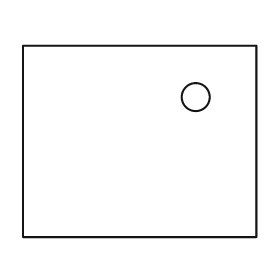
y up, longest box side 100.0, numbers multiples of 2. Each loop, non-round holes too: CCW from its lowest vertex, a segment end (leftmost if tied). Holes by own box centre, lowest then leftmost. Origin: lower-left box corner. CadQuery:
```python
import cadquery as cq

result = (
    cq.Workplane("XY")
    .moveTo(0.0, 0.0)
    .lineTo(100.0, 0.0)
    .lineTo(100.0, 82.0)
    .lineTo(0.0, 82.0)
    .close()
    .moveTo(74.0, 60.0)
    .circle(6.0)
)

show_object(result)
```